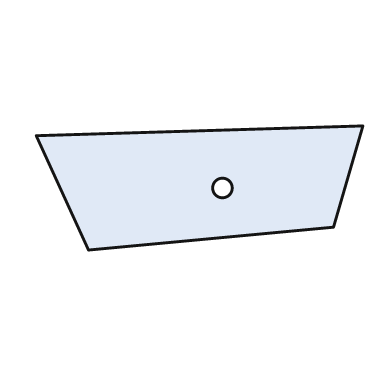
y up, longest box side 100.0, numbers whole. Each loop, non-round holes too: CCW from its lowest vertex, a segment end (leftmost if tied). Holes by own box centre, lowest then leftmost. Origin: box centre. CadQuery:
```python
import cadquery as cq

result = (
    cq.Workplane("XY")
    .moveTo(-34.0, -19.0)
    .lineTo(41.0, -12.0)
    .lineTo(50.0, 19.0)
    .lineTo(-50.0, 16.0)
    .close()
    .moveTo(7.0, 0.0)
    .circle(3.0)
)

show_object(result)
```